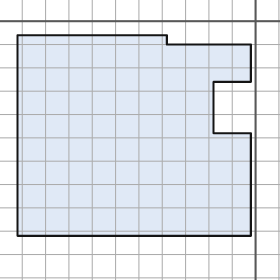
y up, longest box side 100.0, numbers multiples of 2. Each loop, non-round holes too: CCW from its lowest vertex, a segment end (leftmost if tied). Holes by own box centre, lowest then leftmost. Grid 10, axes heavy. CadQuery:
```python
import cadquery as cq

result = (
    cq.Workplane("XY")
    .moveTo(-102.0, -92.0)
    .lineTo(-2.0, -92.0)
    .lineTo(-2.0, -48.0)
    .lineTo(-18.0, -48.0)
    .lineTo(-18.0, -26.0)
    .lineTo(-2.0, -26.0)
    .lineTo(-2.0, -10.0)
    .lineTo(-38.0, -10.0)
    .lineTo(-38.0, -6.0)
    .lineTo(-102.0, -6.0)
    .close()
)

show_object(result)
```